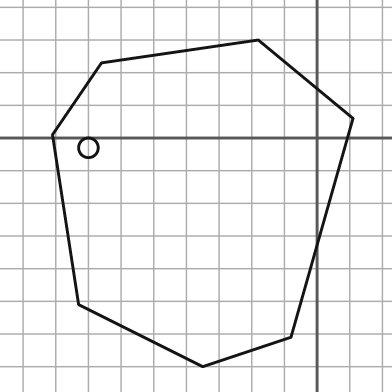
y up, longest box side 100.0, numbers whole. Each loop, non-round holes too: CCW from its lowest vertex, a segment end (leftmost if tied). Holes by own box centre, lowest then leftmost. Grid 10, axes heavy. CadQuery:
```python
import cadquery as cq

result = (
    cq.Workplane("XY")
    .moveTo(-35.0, -70.0)
    .lineTo(-8.0, -61.0)
    .lineTo(11.0, 6.0)
    .lineTo(-18.0, 30.0)
    .lineTo(-66.0, 23.0)
    .lineTo(-81.0, 1.0)
    .lineTo(-73.0, -51.0)
    .close()
    .moveTo(-70.0, -3.0)
    .circle(3.0)
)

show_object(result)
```